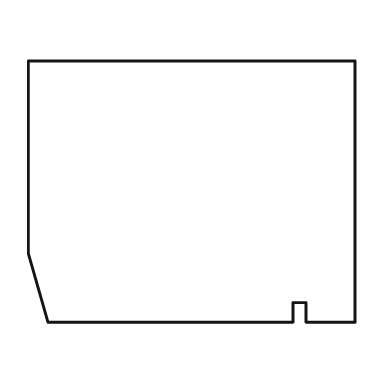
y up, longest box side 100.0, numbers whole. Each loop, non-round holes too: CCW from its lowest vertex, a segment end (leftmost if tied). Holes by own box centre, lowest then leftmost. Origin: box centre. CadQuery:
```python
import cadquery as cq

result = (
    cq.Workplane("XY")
    .moveTo(-44.0, -40.0)
    .lineTo(31.0, -40.0)
    .lineTo(31.0, -34.0)
    .lineTo(35.0, -34.0)
    .lineTo(35.0, -40.0)
    .lineTo(50.0, -40.0)
    .lineTo(50.0, 40.0)
    .lineTo(-50.0, 40.0)
    .lineTo(-50.0, -19.0)
    .close()
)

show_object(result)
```